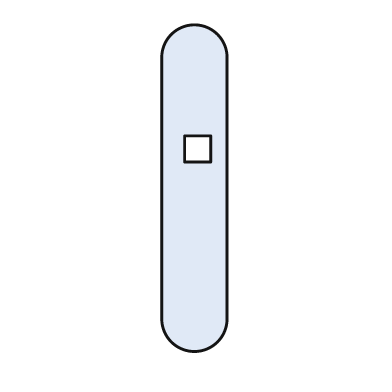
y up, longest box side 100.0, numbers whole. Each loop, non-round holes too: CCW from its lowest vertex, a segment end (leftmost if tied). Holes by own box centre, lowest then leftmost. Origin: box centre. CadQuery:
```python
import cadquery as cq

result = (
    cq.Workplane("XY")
    .moveTo(-10.0, -40.0)
    .threePointArc((0.0, -50.0), (10.0, -40.0))
    .lineTo(10.0, 40.0)
    .threePointArc((0.0, 50.0), (-10.0, 40.0))
    .close()
    .moveTo(-3.0, 8.0)
    .lineTo(5.0, 8.0)
    .lineTo(5.0, 16.0)
    .lineTo(-3.0, 16.0)
    .close()
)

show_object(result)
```